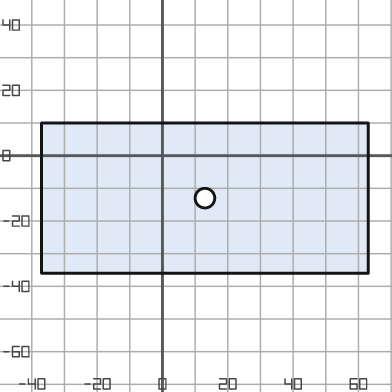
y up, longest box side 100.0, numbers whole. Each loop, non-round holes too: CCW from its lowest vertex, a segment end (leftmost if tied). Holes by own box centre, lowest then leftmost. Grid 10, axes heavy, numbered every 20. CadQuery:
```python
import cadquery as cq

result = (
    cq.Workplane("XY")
    .moveTo(-37.0, -36.0)
    .lineTo(63.0, -36.0)
    .lineTo(63.0, 10.0)
    .lineTo(-37.0, 10.0)
    .close()
    .moveTo(13.0, -13.0)
    .circle(3.0)
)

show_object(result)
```